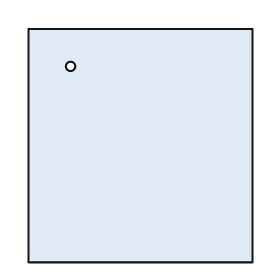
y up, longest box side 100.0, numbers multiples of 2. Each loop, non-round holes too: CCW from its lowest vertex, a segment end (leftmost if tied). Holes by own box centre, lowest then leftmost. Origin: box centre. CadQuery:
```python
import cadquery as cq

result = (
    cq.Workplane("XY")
    .moveTo(-48.0, -50.0)
    .lineTo(48.0, -50.0)
    .lineTo(48.0, 50.0)
    .lineTo(-48.0, 50.0)
    .close()
    .moveTo(-30.0, 34.0)
    .circle(2.0)
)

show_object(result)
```